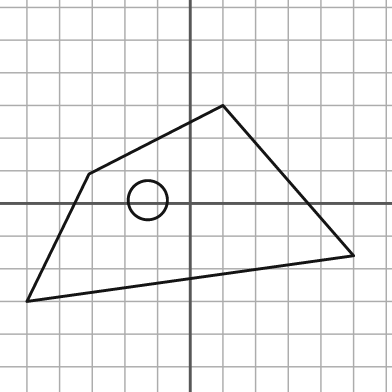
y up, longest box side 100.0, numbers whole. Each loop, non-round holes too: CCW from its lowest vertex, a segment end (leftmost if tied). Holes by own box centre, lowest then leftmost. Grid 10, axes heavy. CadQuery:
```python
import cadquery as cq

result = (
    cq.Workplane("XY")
    .moveTo(-50.0, -30.0)
    .lineTo(50.0, -16.0)
    .lineTo(10.0, 30.0)
    .lineTo(-31.0, 9.0)
    .close()
    .moveTo(-13.0, 1.0)
    .circle(6.0)
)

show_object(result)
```